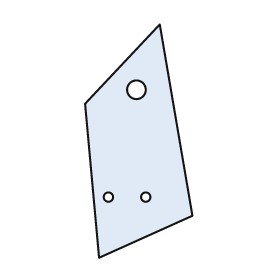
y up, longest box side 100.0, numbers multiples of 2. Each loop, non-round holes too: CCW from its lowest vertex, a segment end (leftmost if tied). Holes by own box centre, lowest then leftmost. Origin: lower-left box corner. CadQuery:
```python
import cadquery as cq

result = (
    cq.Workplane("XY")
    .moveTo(6.0, 0.0)
    .lineTo(46.0, 18.0)
    .lineTo(32.0, 100.0)
    .lineTo(0.0, 66.0)
    .close()
    .moveTo(10.0, 26.0)
    .circle(2.0)
    .moveTo(26.0, 26.0)
    .circle(2.0)
    .moveTo(22.0, 72.0)
    .circle(4.0)
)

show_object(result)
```